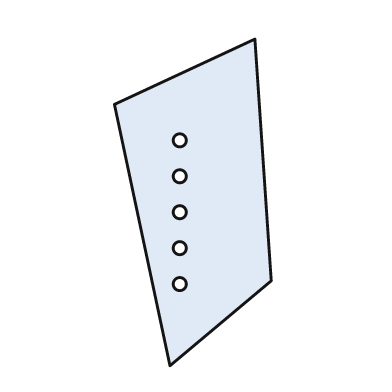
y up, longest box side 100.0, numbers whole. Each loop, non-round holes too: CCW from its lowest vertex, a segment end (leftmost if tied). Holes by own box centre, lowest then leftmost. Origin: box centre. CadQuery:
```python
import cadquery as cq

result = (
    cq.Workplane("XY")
    .moveTo(-7.0, -50.0)
    .lineTo(24.0, -24.0)
    .lineTo(19.0, 50.0)
    .lineTo(-24.0, 30.0)
    .close()
    .moveTo(-4.0, -25.0)
    .circle(2.0)
    .moveTo(-4.0, -14.0)
    .circle(2.0)
    .moveTo(-4.0, -3.0)
    .circle(2.0)
    .moveTo(-4.0, 8.0)
    .circle(2.0)
    .moveTo(-4.0, 19.0)
    .circle(2.0)
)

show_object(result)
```